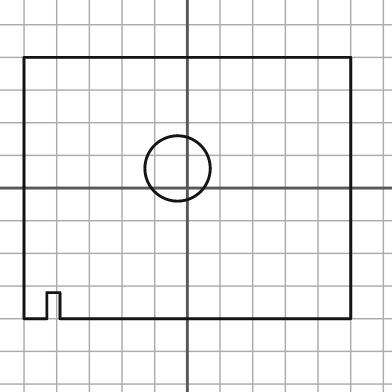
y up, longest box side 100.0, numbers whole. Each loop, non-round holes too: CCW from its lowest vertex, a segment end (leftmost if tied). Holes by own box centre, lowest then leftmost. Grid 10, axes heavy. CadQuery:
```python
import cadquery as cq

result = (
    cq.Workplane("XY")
    .moveTo(-50.0, -40.0)
    .lineTo(-43.0, -40.0)
    .lineTo(-43.0, -32.0)
    .lineTo(-39.0, -32.0)
    .lineTo(-39.0, -40.0)
    .lineTo(50.0, -40.0)
    .lineTo(50.0, 40.0)
    .lineTo(-50.0, 40.0)
    .close()
    .moveTo(-3.0, 6.0)
    .circle(10.0)
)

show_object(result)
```